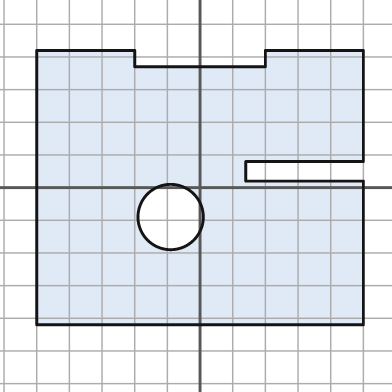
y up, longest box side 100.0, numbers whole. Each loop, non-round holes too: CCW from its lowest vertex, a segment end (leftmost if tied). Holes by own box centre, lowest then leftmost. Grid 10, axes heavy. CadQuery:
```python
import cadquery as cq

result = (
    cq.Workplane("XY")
    .moveTo(-50.0, -42.0)
    .lineTo(50.0, -42.0)
    .lineTo(50.0, 2.0)
    .lineTo(14.0, 2.0)
    .lineTo(14.0, 8.0)
    .lineTo(50.0, 8.0)
    .lineTo(50.0, 42.0)
    .lineTo(20.0, 42.0)
    .lineTo(20.0, 37.0)
    .lineTo(-20.0, 37.0)
    .lineTo(-20.0, 42.0)
    .lineTo(-50.0, 42.0)
    .close()
    .moveTo(-9.0, -9.0)
    .circle(10.0)
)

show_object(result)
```